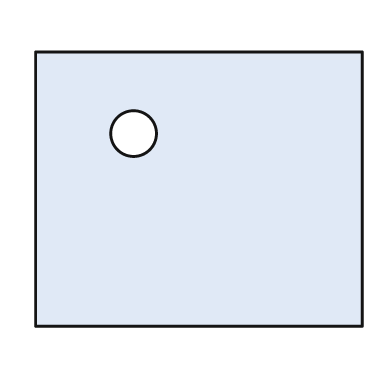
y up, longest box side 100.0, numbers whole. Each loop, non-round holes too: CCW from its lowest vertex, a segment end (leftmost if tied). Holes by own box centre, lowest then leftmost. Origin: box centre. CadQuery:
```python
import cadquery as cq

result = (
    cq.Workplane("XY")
    .moveTo(-50.0, -42.0)
    .lineTo(50.0, -42.0)
    .lineTo(50.0, 42.0)
    .lineTo(-50.0, 42.0)
    .close()
    .moveTo(-20.0, 17.0)
    .circle(7.0)
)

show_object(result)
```